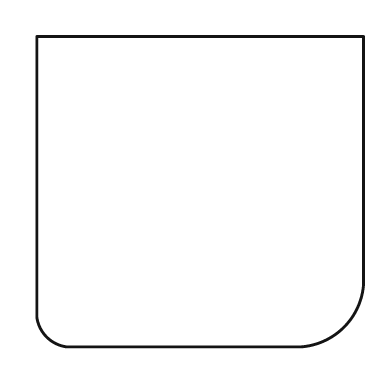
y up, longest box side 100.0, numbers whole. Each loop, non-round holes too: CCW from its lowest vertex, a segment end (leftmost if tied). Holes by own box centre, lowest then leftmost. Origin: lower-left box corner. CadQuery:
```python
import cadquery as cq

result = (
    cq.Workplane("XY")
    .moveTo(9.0, 0.0)
    .lineTo(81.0, 0.0)
    .threePointArc((94.0, 6.0), (100.0, 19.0))
    .lineTo(100.0, 95.0)
    .lineTo(0.0, 95.0)
    .lineTo(0.0, 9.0)
    .threePointArc((3.0, 3.0), (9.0, 0.0))
    .close()
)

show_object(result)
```